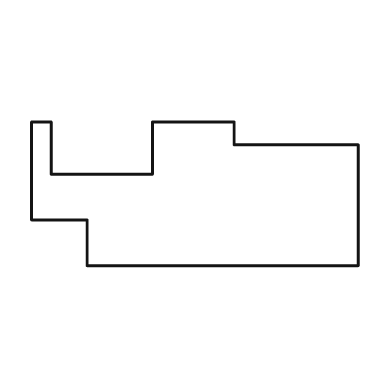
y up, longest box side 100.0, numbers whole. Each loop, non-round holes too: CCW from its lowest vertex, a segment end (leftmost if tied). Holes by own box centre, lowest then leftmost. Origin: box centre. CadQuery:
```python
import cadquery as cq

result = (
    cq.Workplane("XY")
    .moveTo(-33.0, -22.0)
    .lineTo(50.0, -22.0)
    .lineTo(50.0, 15.0)
    .lineTo(12.0, 15.0)
    .lineTo(12.0, 22.0)
    .lineTo(-13.0, 22.0)
    .lineTo(-13.0, 6.0)
    .lineTo(-44.0, 6.0)
    .lineTo(-44.0, 22.0)
    .lineTo(-50.0, 22.0)
    .lineTo(-50.0, -8.0)
    .lineTo(-33.0, -8.0)
    .close()
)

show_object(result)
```